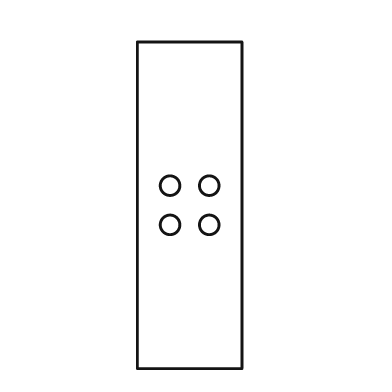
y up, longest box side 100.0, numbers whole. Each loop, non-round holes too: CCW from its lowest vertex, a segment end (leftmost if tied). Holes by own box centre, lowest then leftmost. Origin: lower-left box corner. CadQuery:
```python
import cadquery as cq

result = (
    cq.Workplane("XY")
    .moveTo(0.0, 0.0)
    .lineTo(32.0, 0.0)
    .lineTo(32.0, 100.0)
    .lineTo(0.0, 100.0)
    .close()
    .moveTo(10.0, 44.0)
    .circle(3.0)
    .moveTo(22.0, 44.0)
    .circle(3.0)
    .moveTo(10.0, 56.0)
    .circle(3.0)
    .moveTo(22.0, 56.0)
    .circle(3.0)
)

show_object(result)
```